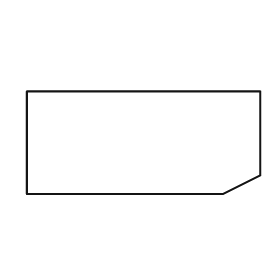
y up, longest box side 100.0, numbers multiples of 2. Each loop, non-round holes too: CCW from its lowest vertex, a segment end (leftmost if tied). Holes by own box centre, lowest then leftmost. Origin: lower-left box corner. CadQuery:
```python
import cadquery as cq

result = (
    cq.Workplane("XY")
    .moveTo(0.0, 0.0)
    .lineTo(84.0, 0.0)
    .lineTo(100.0, 8.0)
    .lineTo(100.0, 44.0)
    .lineTo(0.0, 44.0)
    .close()
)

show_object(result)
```